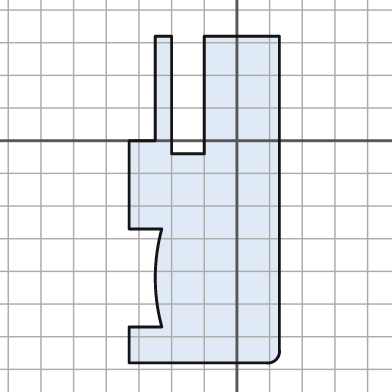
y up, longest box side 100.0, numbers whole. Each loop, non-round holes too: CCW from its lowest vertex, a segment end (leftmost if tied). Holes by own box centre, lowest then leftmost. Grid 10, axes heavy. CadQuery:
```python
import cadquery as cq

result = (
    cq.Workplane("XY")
    .moveTo(-33.0, -68.0)
    .lineTo(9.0, -68.0)
    .threePointArc((12.0, -67.0), (13.0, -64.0))
    .lineTo(13.0, 32.0)
    .lineTo(-10.0, 32.0)
    .lineTo(-10.0, -4.0)
    .lineTo(-20.0, -4.0)
    .lineTo(-20.0, 32.0)
    .lineTo(-25.0, 32.0)
    .lineTo(-25.0, 0.0)
    .lineTo(-33.0, 0.0)
    .lineTo(-33.0, -27.0)
    .lineTo(-23.0, -27.0)
    .threePointArc((-25.0, -42.0), (-23.0, -57.0))
    .lineTo(-33.0, -57.0)
    .close()
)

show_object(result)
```